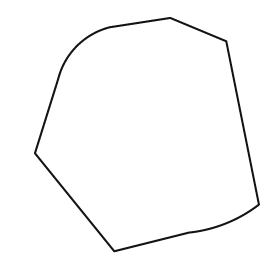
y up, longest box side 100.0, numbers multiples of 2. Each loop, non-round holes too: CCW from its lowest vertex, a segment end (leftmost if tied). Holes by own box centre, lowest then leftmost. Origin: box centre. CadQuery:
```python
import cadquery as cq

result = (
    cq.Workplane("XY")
    .moveTo(-14.0, -50.0)
    .lineTo(18.0, -42.0)
    .threePointArc((34.0, -38.0), (48.0, -30.0))
    .lineTo(34.0, 40.0)
    .lineTo(10.0, 50.0)
    .lineTo(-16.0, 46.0)
    .threePointArc((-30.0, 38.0), (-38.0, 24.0))
    .lineTo(-48.0, -8.0)
    .close()
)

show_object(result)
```